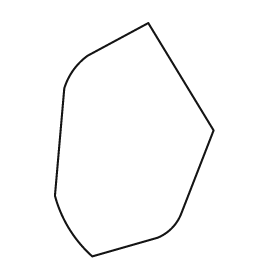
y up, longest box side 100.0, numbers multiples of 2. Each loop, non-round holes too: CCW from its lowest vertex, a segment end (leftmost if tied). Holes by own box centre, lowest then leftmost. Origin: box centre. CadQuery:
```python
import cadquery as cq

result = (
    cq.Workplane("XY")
    .moveTo(-18.0, -50.0)
    .lineTo(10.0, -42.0)
    .threePointArc((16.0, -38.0), (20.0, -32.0))
    .lineTo(34.0, 4.0)
    .lineTo(6.0, 50.0)
    .lineTo(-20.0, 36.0)
    .threePointArc((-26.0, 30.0), (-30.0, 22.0))
    .lineTo(-34.0, -24.0)
    .threePointArc((-28.0, -38.0), (-18.0, -50.0))
    .close()
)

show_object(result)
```